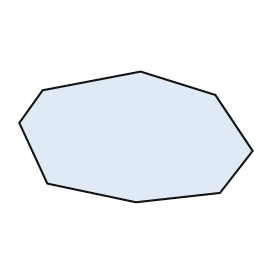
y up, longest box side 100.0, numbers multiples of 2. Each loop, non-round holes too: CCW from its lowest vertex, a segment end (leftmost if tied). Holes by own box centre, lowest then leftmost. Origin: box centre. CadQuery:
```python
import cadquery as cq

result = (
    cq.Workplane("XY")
    .moveTo(0.0, -28.0)
    .lineTo(36.0, -24.0)
    .lineTo(50.0, -6.0)
    .lineTo(34.0, 18.0)
    .lineTo(2.0, 28.0)
    .lineTo(-40.0, 20.0)
    .lineTo(-50.0, 6.0)
    .lineTo(-38.0, -20.0)
    .close()
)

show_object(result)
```